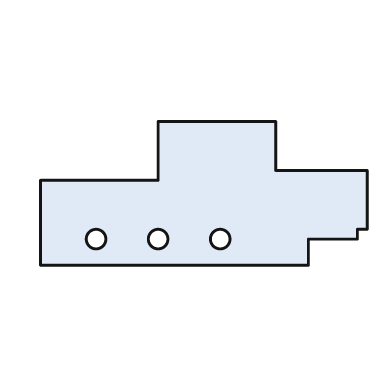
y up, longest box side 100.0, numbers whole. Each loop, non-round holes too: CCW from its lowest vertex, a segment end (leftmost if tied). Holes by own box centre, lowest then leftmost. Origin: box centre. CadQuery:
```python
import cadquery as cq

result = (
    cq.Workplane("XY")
    .moveTo(-50.0, -22.0)
    .lineTo(32.0, -22.0)
    .lineTo(32.0, -14.0)
    .lineTo(47.0, -14.0)
    .lineTo(47.0, -11.0)
    .lineTo(50.0, -11.0)
    .lineTo(50.0, 7.0)
    .lineTo(22.0, 7.0)
    .lineTo(22.0, 22.0)
    .lineTo(-14.0, 22.0)
    .lineTo(-14.0, 4.0)
    .lineTo(-50.0, 4.0)
    .close()
    .moveTo(-33.0, -14.0)
    .circle(3.0)
    .moveTo(-14.0, -14.0)
    .circle(3.0)
    .moveTo(5.0, -14.0)
    .circle(3.0)
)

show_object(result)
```